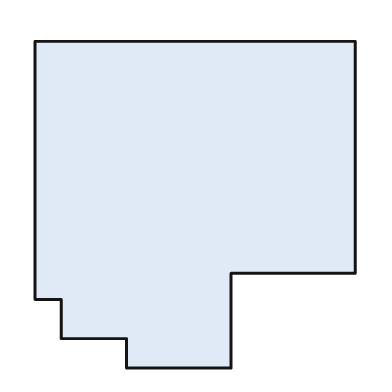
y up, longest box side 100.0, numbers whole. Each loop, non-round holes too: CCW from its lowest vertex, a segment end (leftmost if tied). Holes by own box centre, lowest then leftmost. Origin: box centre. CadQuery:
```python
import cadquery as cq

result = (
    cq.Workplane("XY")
    .moveTo(-21.0, -50.0)
    .lineTo(11.0, -50.0)
    .lineTo(11.0, -21.0)
    .lineTo(49.0, -21.0)
    .lineTo(49.0, 50.0)
    .lineTo(-49.0, 50.0)
    .lineTo(-49.0, -29.0)
    .lineTo(-41.0, -29.0)
    .lineTo(-41.0, -41.0)
    .lineTo(-21.0, -41.0)
    .close()
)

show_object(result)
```